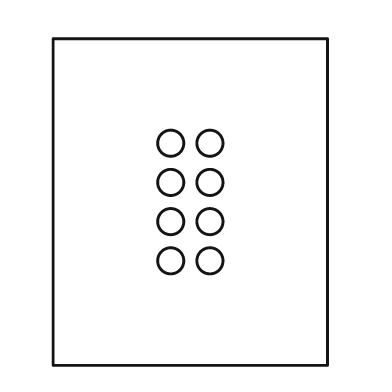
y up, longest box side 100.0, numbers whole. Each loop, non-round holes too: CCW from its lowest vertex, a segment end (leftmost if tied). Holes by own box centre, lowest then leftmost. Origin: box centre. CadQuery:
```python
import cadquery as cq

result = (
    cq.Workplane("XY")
    .moveTo(-42.0, -50.0)
    .lineTo(42.0, -50.0)
    .lineTo(42.0, 50.0)
    .lineTo(-42.0, 50.0)
    .close()
    .moveTo(-6.0, -18.0)
    .circle(4.0)
    .moveTo(6.0, -18.0)
    .circle(4.0)
    .moveTo(-6.0, -6.0)
    .circle(4.0)
    .moveTo(6.0, -6.0)
    .circle(4.0)
    .moveTo(-6.0, 6.0)
    .circle(4.0)
    .moveTo(6.0, 6.0)
    .circle(4.0)
    .moveTo(-6.0, 18.0)
    .circle(4.0)
    .moveTo(6.0, 18.0)
    .circle(4.0)
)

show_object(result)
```